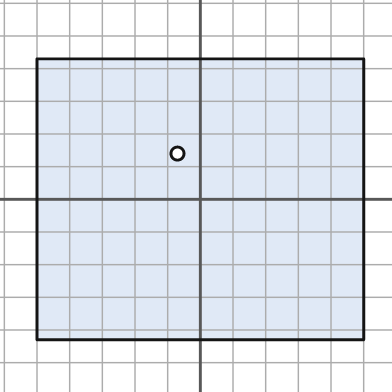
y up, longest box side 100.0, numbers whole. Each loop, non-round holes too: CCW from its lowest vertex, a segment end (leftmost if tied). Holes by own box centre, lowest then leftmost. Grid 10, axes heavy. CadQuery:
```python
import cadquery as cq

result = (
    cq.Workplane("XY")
    .moveTo(-50.0, -43.0)
    .lineTo(50.0, -43.0)
    .lineTo(50.0, 43.0)
    .lineTo(-50.0, 43.0)
    .close()
    .moveTo(-7.0, 14.0)
    .circle(2.0)
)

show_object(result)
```